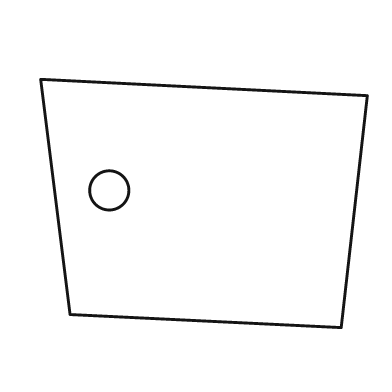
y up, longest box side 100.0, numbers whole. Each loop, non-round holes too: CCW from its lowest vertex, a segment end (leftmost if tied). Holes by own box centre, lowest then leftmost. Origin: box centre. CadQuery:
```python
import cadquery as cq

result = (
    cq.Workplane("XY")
    .moveTo(42.0, -38.0)
    .lineTo(50.0, 33.0)
    .lineTo(-50.0, 38.0)
    .lineTo(-41.0, -34.0)
    .close()
    .moveTo(-29.0, 4.0)
    .circle(6.0)
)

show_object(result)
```